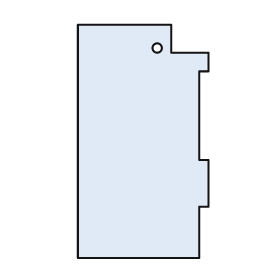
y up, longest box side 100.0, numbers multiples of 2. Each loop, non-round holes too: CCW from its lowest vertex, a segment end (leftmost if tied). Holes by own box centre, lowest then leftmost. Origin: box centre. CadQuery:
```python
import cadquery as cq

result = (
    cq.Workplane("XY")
    .moveTo(-28.0, -50.0)
    .lineTo(24.0, -50.0)
    .lineTo(24.0, -28.0)
    .lineTo(28.0, -28.0)
    .lineTo(28.0, -8.0)
    .lineTo(24.0, -8.0)
    .lineTo(24.0, 30.0)
    .lineTo(28.0, 30.0)
    .lineTo(28.0, 38.0)
    .lineTo(12.0, 38.0)
    .lineTo(12.0, 50.0)
    .lineTo(-28.0, 50.0)
    .close()
    .moveTo(6.0, 40.0)
    .circle(2.0)
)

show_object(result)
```